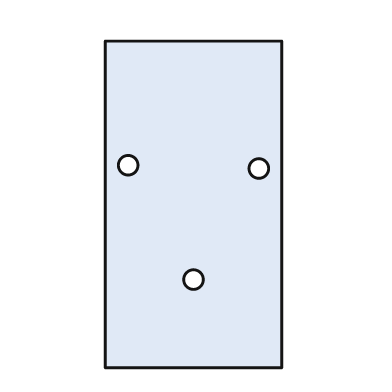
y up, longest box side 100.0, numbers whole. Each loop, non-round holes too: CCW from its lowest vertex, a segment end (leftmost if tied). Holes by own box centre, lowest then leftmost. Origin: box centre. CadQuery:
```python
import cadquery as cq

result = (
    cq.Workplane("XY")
    .moveTo(-27.0, -50.0)
    .lineTo(27.0, -50.0)
    .lineTo(27.0, 50.0)
    .lineTo(-27.0, 50.0)
    .close()
    .moveTo(0.0, -23.0)
    .circle(3.0)
    .moveTo(20.0, 11.0)
    .circle(3.0)
    .moveTo(-20.0, 12.0)
    .circle(3.0)
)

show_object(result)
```